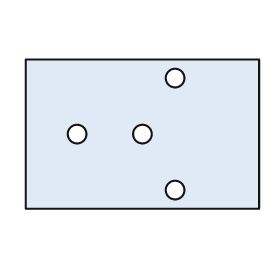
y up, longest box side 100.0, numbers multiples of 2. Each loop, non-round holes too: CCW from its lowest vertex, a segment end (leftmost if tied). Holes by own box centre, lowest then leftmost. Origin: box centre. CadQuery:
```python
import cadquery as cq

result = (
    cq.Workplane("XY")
    .moveTo(-50.0, -32.0)
    .lineTo(50.0, -32.0)
    .lineTo(50.0, 32.0)
    .lineTo(-50.0, 32.0)
    .close()
    .moveTo(14.0, -24.0)
    .circle(4.0)
    .moveTo(-28.0, 0.0)
    .circle(4.0)
    .moveTo(0.0, 0.0)
    .circle(4.0)
    .moveTo(14.0, 24.0)
    .circle(4.0)
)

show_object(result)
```